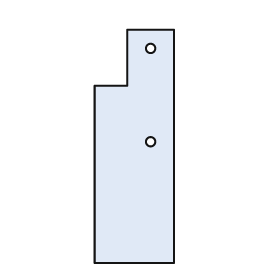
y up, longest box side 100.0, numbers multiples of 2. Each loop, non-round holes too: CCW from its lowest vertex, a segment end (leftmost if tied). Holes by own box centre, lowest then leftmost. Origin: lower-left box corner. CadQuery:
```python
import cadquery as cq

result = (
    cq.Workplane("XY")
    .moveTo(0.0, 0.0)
    .lineTo(34.0, 0.0)
    .lineTo(34.0, 100.0)
    .lineTo(14.0, 100.0)
    .lineTo(14.0, 76.0)
    .lineTo(0.0, 76.0)
    .close()
    .moveTo(24.0, 52.0)
    .circle(2.0)
    .moveTo(24.0, 92.0)
    .circle(2.0)
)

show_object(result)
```